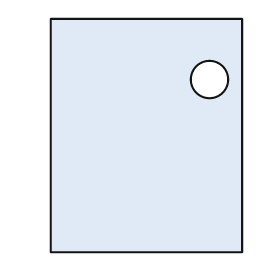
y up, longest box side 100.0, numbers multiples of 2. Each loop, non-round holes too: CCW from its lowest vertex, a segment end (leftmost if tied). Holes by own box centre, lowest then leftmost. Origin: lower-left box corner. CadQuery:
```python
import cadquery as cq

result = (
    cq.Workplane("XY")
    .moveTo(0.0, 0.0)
    .lineTo(82.0, 0.0)
    .lineTo(82.0, 100.0)
    .lineTo(0.0, 100.0)
    .close()
    .moveTo(68.0, 74.0)
    .circle(8.0)
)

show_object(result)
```